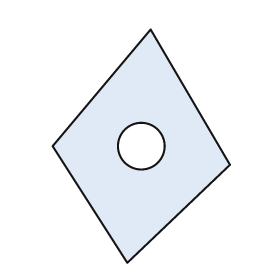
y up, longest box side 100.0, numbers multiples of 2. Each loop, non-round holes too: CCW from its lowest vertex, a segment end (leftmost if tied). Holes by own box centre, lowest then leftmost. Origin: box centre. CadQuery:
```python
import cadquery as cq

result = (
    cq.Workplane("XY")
    .moveTo(-6.0, -50.0)
    .lineTo(38.0, -8.0)
    .lineTo(4.0, 50.0)
    .lineTo(-38.0, 0.0)
    .close()
    .moveTo(0.0, 0.0)
    .circle(10.0)
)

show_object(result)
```